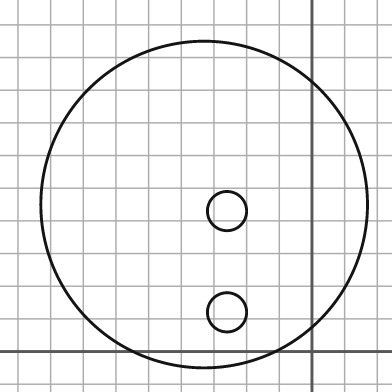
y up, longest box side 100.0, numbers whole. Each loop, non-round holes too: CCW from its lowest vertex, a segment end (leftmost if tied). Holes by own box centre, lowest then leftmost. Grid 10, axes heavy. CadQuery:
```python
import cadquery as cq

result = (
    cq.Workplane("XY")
    .moveTo(-33.0, 45.0)
    .circle(50.0)
    .moveTo(-26.0, 12.0)
    .circle(6.0)
    .moveTo(-26.0, 43.0)
    .circle(6.0)
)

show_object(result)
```